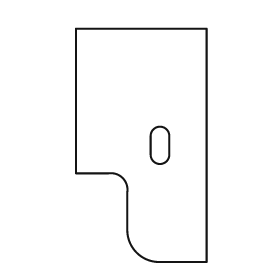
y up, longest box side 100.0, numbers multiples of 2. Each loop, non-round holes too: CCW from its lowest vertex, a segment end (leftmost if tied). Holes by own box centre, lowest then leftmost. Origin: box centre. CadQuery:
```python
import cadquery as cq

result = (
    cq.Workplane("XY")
    .moveTo(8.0, -50.0)
    .lineTo(28.0, -50.0)
    .lineTo(28.0, 50.0)
    .lineTo(-28.0, 50.0)
    .lineTo(-28.0, -12.0)
    .lineTo(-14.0, -12.0)
    .threePointArc((-8.0, -14.0), (-6.0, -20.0))
    .lineTo(-6.0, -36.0)
    .threePointArc((-2.0, -46.0), (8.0, -50.0))
    .close()
    .moveTo(4.0, -4.0)
    .threePointArc((8.0, -8.0), (12.0, -4.0))
    .lineTo(12.0, 4.0)
    .threePointArc((8.0, 8.0), (4.0, 4.0))
    .close()
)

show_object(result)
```